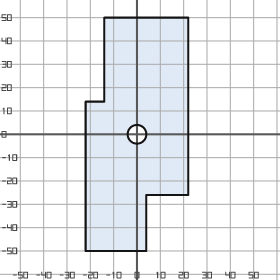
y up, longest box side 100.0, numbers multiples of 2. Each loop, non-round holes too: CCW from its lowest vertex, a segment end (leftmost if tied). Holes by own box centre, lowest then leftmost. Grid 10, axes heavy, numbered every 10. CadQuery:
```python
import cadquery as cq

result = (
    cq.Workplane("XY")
    .moveTo(-22.0, -50.0)
    .lineTo(4.0, -50.0)
    .lineTo(4.0, -26.0)
    .lineTo(22.0, -26.0)
    .lineTo(22.0, 50.0)
    .lineTo(-14.0, 50.0)
    .lineTo(-14.0, 14.0)
    .lineTo(-22.0, 14.0)
    .close()
    .moveTo(0.0, 0.0)
    .circle(4.0)
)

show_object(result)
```